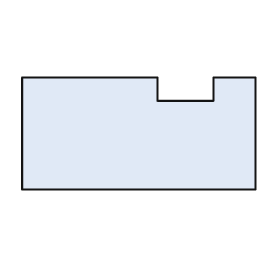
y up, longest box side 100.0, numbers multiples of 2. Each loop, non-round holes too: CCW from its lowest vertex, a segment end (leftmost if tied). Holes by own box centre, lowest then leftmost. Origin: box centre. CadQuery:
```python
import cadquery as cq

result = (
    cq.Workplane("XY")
    .moveTo(-50.0, -24.0)
    .lineTo(50.0, -24.0)
    .lineTo(50.0, 24.0)
    .lineTo(32.0, 24.0)
    .lineTo(32.0, 14.0)
    .lineTo(8.0, 14.0)
    .lineTo(8.0, 24.0)
    .lineTo(-50.0, 24.0)
    .close()
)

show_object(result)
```